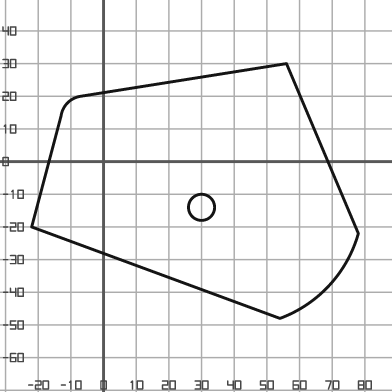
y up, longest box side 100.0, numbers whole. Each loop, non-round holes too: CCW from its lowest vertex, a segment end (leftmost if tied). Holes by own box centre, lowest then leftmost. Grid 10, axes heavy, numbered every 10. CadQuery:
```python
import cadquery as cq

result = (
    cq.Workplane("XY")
    .moveTo(54.0, -48.0)
    .threePointArc((69.0, -38.0), (78.0, -22.0))
    .lineTo(56.0, 30.0)
    .lineTo(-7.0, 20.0)
    .threePointArc((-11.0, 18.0), (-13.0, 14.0))
    .lineTo(-22.0, -20.0)
    .close()
    .moveTo(30.0, -14.0)
    .circle(4.0)
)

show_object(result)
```